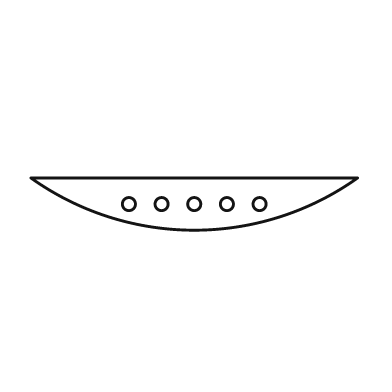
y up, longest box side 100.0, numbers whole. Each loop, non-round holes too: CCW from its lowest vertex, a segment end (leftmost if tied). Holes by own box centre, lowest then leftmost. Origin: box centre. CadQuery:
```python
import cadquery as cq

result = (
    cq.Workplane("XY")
    .moveTo(-50.0, 8.0)
    .threePointArc((0.0, -8.0), (50.0, 8.0))
    .close()
    .moveTo(-20.0, 0.0)
    .circle(2.0)
    .moveTo(-10.0, 0.0)
    .circle(2.0)
    .moveTo(0.0, 0.0)
    .circle(2.0)
    .moveTo(10.0, 0.0)
    .circle(2.0)
    .moveTo(20.0, 0.0)
    .circle(2.0)
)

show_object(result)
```